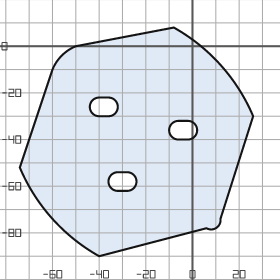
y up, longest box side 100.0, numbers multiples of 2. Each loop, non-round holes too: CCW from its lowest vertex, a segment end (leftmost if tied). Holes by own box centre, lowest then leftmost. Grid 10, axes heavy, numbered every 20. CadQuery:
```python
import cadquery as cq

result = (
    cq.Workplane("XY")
    .moveTo(-40.0, -90.0)
    .lineTo(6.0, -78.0)
    .threePointArc((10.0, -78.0), (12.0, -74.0))
    .lineTo(26.0, -30.0)
    .threePointArc((12.0, -8.0), (-8.0, 8.0))
    .lineTo(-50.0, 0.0)
    .threePointArc((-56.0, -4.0), (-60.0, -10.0))
    .lineTo(-74.0, -52.0)
    .threePointArc((-60.0, -74.0), (-40.0, -90.0))
    .close()
    .moveTo(-32.0, -62.0)
    .lineTo(-28.0, -62.0)
    .threePointArc((-24.0, -58.0), (-28.0, -54.0))
    .lineTo(-32.0, -54.0)
    .threePointArc((-36.0, -58.0), (-32.0, -62.0))
    .close()
    .moveTo(-6.0, -40.0)
    .lineTo(-2.0, -40.0)
    .threePointArc((2.0, -36.0), (-2.0, -32.0))
    .lineTo(-6.0, -32.0)
    .threePointArc((-10.0, -36.0), (-6.0, -40.0))
    .close()
    .moveTo(-40.0, -30.0)
    .lineTo(-36.0, -30.0)
    .threePointArc((-32.0, -26.0), (-36.0, -22.0))
    .lineTo(-40.0, -22.0)
    .threePointArc((-44.0, -26.0), (-40.0, -30.0))
    .close()
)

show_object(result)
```